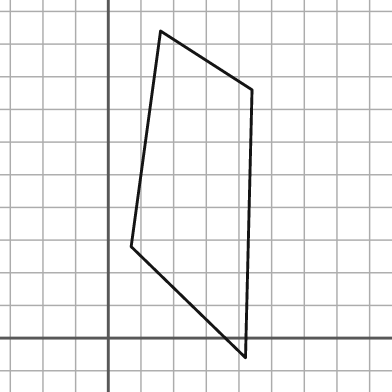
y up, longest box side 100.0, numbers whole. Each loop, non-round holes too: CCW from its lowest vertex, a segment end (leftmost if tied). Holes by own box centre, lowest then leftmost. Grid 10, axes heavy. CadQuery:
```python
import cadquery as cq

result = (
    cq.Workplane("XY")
    .moveTo(42.0, -6.0)
    .lineTo(44.0, 76.0)
    .lineTo(16.0, 94.0)
    .lineTo(7.0, 28.0)
    .close()
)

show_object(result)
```